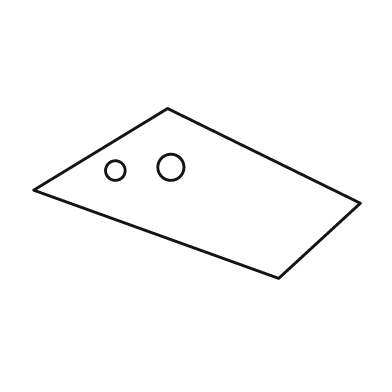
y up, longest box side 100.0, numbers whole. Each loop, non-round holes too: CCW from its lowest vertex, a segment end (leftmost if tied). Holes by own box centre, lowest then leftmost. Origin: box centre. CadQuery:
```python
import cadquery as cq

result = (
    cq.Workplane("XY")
    .moveTo(25.0, -26.0)
    .lineTo(50.0, -3.0)
    .lineTo(-9.0, 26.0)
    .lineTo(-50.0, 1.0)
    .close()
    .moveTo(-25.0, 7.0)
    .circle(3.0)
    .moveTo(-8.0, 8.0)
    .circle(4.0)
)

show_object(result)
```